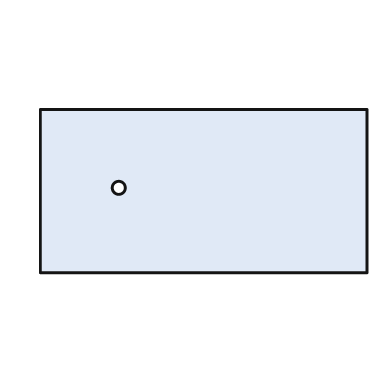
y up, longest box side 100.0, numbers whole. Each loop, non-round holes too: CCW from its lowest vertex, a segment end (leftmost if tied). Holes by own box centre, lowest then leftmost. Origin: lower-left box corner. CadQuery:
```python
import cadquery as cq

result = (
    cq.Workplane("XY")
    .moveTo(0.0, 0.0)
    .lineTo(100.0, 0.0)
    .lineTo(100.0, 50.0)
    .lineTo(0.0, 50.0)
    .close()
    .moveTo(24.0, 26.0)
    .circle(2.0)
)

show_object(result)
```